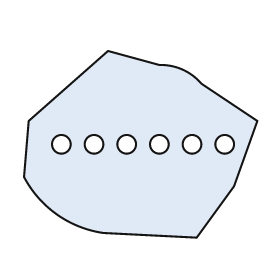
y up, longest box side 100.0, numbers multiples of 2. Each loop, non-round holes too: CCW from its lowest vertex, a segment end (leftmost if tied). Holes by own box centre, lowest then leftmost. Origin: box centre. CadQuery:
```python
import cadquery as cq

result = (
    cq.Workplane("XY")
    .moveTo(24.0, -40.0)
    .lineTo(40.0, -18.0)
    .lineTo(50.0, 10.0)
    .lineTo(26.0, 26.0)
    .threePointArc((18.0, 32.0), (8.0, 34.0))
    .lineTo(-14.0, 40.0)
    .lineTo(-48.0, 10.0)
    .lineTo(-50.0, -14.0)
    .threePointArc((-36.0, -30.0), (-16.0, -38.0))
    .close()
    .moveTo(-34.0, 0.0)
    .circle(4.0)
    .moveTo(-20.0, 0.0)
    .circle(4.0)
    .moveTo(-6.0, 0.0)
    .circle(4.0)
    .moveTo(8.0, 0.0)
    .circle(4.0)
    .moveTo(22.0, 0.0)
    .circle(4.0)
    .moveTo(36.0, 0.0)
    .circle(4.0)
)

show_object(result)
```